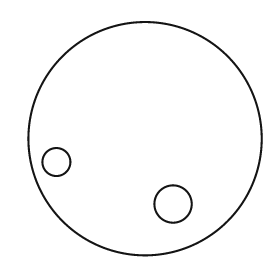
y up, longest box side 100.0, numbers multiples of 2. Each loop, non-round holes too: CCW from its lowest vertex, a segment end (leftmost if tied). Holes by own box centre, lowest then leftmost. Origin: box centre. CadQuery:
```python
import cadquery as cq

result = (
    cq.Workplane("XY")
    .moveTo(0.0, 0.0)
    .circle(50.0)
    .moveTo(12.0, -28.0)
    .circle(8.0)
    .moveTo(-38.0, -10.0)
    .circle(6.0)
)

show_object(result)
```